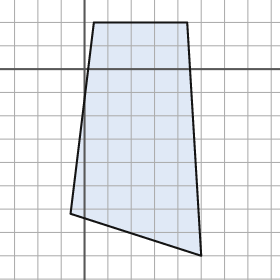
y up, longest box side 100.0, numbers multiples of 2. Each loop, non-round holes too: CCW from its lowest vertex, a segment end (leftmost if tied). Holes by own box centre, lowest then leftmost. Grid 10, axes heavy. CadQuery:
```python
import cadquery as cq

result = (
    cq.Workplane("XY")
    .moveTo(50.0, -80.0)
    .lineTo(44.0, 20.0)
    .lineTo(4.0, 20.0)
    .lineTo(-6.0, -62.0)
    .close()
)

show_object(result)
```